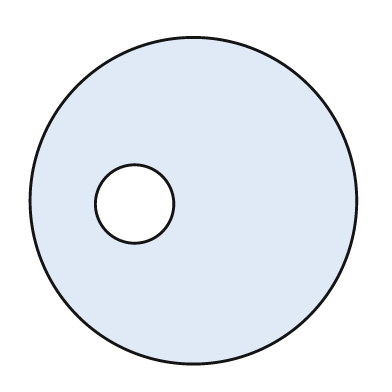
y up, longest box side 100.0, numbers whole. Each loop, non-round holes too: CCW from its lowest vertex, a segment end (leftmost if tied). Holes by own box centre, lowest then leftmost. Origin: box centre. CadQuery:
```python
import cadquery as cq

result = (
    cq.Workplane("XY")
    .moveTo(0.0, 0.0)
    .circle(50.0)
    .moveTo(-18.0, -1.0)
    .circle(12.0)
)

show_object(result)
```